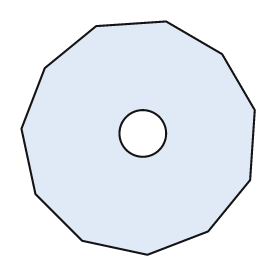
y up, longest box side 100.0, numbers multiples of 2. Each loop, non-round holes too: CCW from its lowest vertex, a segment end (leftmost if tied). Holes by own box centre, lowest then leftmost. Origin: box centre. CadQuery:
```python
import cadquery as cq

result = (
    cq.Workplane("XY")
    .moveTo(4.0, -50.0)
    .lineTo(30.0, -40.0)
    .lineTo(48.0, -18.0)
    .lineTo(50.0, 12.0)
    .lineTo(36.0, 36.0)
    .lineTo(12.0, 50.0)
    .lineTo(-18.0, 48.0)
    .lineTo(-40.0, 30.0)
    .lineTo(-50.0, 4.0)
    .lineTo(-44.0, -24.0)
    .lineTo(-24.0, -44.0)
    .close()
    .moveTo(2.0, 2.0)
    .circle(10.0)
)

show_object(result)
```